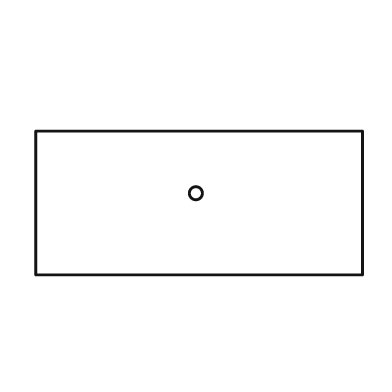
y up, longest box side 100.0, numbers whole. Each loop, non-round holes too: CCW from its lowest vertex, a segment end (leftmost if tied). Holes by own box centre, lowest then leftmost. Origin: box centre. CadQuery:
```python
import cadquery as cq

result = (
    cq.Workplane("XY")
    .moveTo(-50.0, -22.0)
    .lineTo(50.0, -22.0)
    .lineTo(50.0, 22.0)
    .lineTo(-50.0, 22.0)
    .close()
    .moveTo(-1.0, 3.0)
    .circle(2.0)
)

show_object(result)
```